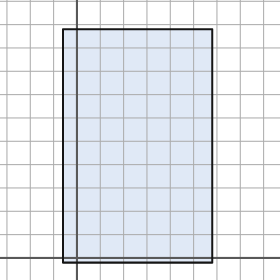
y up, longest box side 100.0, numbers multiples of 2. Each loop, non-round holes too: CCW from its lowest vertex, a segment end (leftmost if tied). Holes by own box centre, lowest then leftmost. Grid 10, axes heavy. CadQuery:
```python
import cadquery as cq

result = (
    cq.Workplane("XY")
    .moveTo(-6.0, -2.0)
    .lineTo(58.0, -2.0)
    .lineTo(58.0, 98.0)
    .lineTo(-6.0, 98.0)
    .close()
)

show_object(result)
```